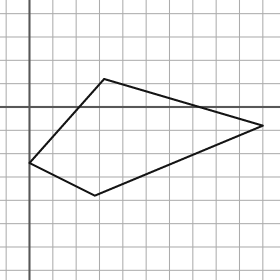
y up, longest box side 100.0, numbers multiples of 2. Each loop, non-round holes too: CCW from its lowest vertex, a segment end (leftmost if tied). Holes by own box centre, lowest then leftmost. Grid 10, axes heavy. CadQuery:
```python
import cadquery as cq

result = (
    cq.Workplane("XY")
    .moveTo(28.0, -38.0)
    .lineTo(100.0, -8.0)
    .lineTo(32.0, 12.0)
    .lineTo(0.0, -24.0)
    .close()
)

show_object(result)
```